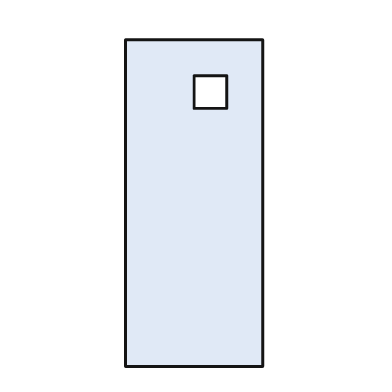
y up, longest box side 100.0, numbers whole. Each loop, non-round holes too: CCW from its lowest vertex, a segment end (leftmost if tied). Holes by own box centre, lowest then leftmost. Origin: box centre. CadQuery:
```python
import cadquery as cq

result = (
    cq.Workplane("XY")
    .moveTo(-21.0, -50.0)
    .lineTo(21.0, -50.0)
    .lineTo(21.0, 50.0)
    .lineTo(-21.0, 50.0)
    .close()
    .moveTo(0.0, 29.0)
    .lineTo(10.0, 29.0)
    .lineTo(10.0, 39.0)
    .lineTo(0.0, 39.0)
    .close()
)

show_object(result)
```